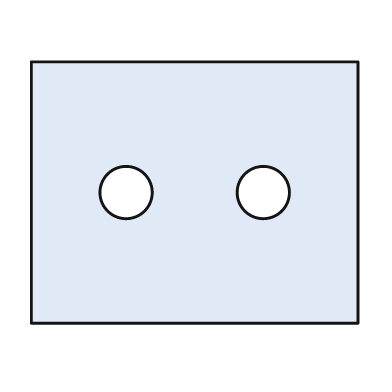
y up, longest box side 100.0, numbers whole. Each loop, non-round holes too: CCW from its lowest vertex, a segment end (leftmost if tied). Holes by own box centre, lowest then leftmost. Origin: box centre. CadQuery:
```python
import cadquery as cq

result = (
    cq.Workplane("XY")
    .moveTo(-50.0, -40.0)
    .lineTo(50.0, -40.0)
    .lineTo(50.0, 40.0)
    .lineTo(-50.0, 40.0)
    .close()
    .moveTo(-21.0, 0.0)
    .circle(8.0)
    .moveTo(21.0, 0.0)
    .circle(8.0)
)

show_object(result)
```